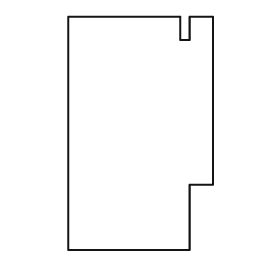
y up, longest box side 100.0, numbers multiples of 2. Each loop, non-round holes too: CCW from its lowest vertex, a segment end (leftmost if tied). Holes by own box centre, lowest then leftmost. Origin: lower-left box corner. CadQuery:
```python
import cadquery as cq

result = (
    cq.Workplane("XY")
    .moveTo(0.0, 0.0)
    .lineTo(52.0, 0.0)
    .lineTo(52.0, 28.0)
    .lineTo(62.0, 28.0)
    .lineTo(62.0, 100.0)
    .lineTo(52.0, 100.0)
    .lineTo(52.0, 90.0)
    .lineTo(48.0, 90.0)
    .lineTo(48.0, 100.0)
    .lineTo(0.0, 100.0)
    .close()
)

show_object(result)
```